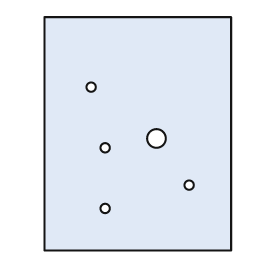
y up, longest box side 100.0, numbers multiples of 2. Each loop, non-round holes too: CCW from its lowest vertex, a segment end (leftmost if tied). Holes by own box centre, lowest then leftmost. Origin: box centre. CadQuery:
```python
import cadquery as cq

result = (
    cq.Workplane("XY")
    .moveTo(-40.0, -50.0)
    .lineTo(40.0, -50.0)
    .lineTo(40.0, 50.0)
    .lineTo(-40.0, 50.0)
    .close()
    .moveTo(-14.0, -32.0)
    .circle(2.0)
    .moveTo(22.0, -22.0)
    .circle(2.0)
    .moveTo(-14.0, -6.0)
    .circle(2.0)
    .moveTo(8.0, -2.0)
    .circle(4.0)
    .moveTo(-20.0, 20.0)
    .circle(2.0)
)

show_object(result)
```